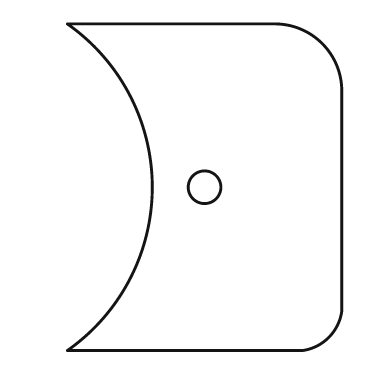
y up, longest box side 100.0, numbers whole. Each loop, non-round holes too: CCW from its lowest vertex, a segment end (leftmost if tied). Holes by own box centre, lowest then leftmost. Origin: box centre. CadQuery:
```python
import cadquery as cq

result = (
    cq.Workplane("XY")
    .moveTo(-42.0, -50.0)
    .lineTo(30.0, -50.0)
    .threePointArc((38.0, -46.0), (42.0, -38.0))
    .lineTo(42.0, 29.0)
    .threePointArc((36.0, 44.0), (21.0, 50.0))
    .lineTo(-42.0, 50.0)
    .threePointArc((-16.0, 0.0), (-42.0, -50.0))
    .close()
    .moveTo(0.0, 0.0)
    .circle(5.0)
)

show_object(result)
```